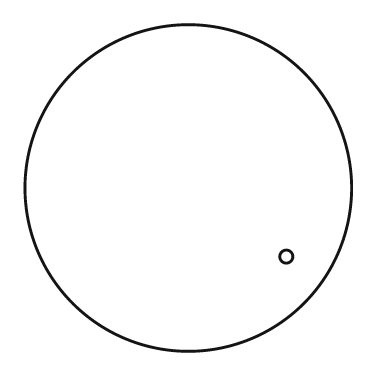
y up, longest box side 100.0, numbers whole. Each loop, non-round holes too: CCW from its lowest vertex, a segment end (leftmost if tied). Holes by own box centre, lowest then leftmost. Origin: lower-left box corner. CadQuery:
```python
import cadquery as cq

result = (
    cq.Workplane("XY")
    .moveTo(50.0, 50.0)
    .circle(50.0)
    .moveTo(80.0, 29.0)
    .circle(2.0)
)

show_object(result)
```